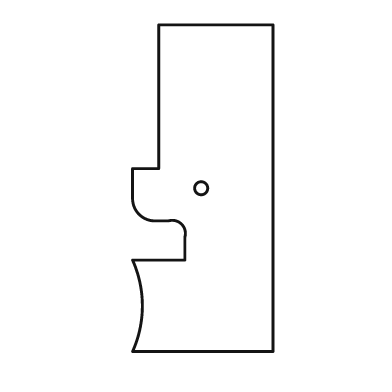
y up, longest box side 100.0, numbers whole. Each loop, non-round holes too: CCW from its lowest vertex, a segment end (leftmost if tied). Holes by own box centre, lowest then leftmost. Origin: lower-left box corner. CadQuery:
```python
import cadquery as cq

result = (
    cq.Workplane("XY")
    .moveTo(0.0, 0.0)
    .lineTo(43.0, 0.0)
    .lineTo(43.0, 100.0)
    .lineTo(8.0, 100.0)
    .lineTo(8.0, 56.0)
    .lineTo(0.0, 56.0)
    .lineTo(0.0, 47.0)
    .threePointArc((2.0, 42.0), (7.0, 40.0))
    .lineTo(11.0, 40.0)
    .threePointArc((15.0, 39.0), (16.0, 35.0))
    .lineTo(16.0, 28.0)
    .lineTo(0.0, 28.0)
    .threePointArc((3.0, 14.0), (0.0, 0.0))
    .close()
    .moveTo(21.0, 50.0)
    .circle(2.0)
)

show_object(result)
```